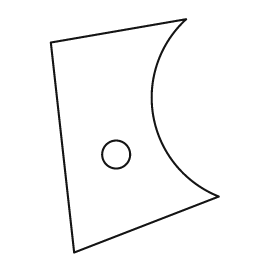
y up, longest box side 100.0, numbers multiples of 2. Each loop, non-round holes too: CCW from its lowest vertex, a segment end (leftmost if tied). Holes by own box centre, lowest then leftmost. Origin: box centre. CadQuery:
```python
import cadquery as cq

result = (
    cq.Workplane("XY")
    .moveTo(-26.0, -50.0)
    .lineTo(36.0, -26.0)
    .threePointArc((8.0, 8.0), (22.0, 50.0))
    .lineTo(-36.0, 40.0)
    .close()
    .moveTo(-8.0, -8.0)
    .circle(6.0)
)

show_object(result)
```